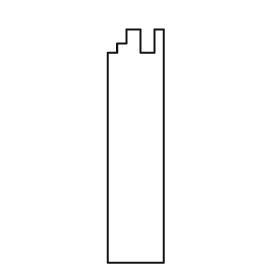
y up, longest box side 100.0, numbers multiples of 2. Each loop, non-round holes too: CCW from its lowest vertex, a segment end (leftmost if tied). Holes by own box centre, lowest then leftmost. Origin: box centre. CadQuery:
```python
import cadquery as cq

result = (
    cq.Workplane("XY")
    .moveTo(-12.0, -50.0)
    .lineTo(12.0, -50.0)
    .lineTo(12.0, 50.0)
    .lineTo(8.0, 50.0)
    .lineTo(8.0, 40.0)
    .lineTo(2.0, 40.0)
    .lineTo(2.0, 50.0)
    .lineTo(-4.0, 50.0)
    .lineTo(-4.0, 44.0)
    .lineTo(-8.0, 44.0)
    .lineTo(-8.0, 40.0)
    .lineTo(-12.0, 40.0)
    .close()
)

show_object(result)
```